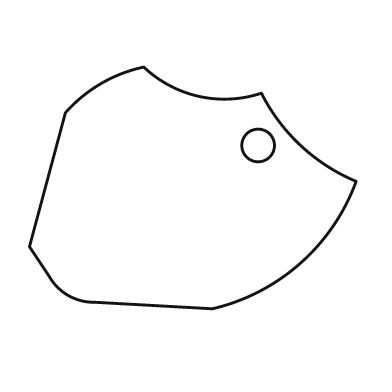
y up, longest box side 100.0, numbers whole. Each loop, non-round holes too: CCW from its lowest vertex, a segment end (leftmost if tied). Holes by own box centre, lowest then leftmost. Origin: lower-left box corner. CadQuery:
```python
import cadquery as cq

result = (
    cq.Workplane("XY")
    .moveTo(56.0, 0.0)
    .threePointArc((83.0, 14.0), (100.0, 39.0))
    .threePointArc((83.0, 50.0), (71.0, 66.0))
    .threePointArc((52.0, 65.0), (35.0, 74.0))
    .threePointArc((22.0, 69.0), (11.0, 60.0))
    .lineTo(0.0, 19.0)
    .lineTo(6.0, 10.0)
    .threePointArc((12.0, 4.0), (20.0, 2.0))
    .close()
    .moveTo(70.0, 50.0)
    .circle(5.0)
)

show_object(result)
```